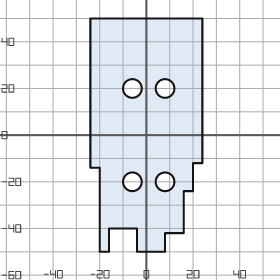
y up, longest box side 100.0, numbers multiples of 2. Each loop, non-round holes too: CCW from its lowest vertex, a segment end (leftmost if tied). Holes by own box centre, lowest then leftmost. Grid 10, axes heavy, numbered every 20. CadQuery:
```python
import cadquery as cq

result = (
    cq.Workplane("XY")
    .moveTo(-20.0, -50.0)
    .lineTo(-16.0, -50.0)
    .lineTo(-16.0, -40.0)
    .lineTo(-4.0, -40.0)
    .lineTo(-4.0, -50.0)
    .lineTo(8.0, -50.0)
    .lineTo(8.0, -42.0)
    .lineTo(16.0, -42.0)
    .lineTo(16.0, -24.0)
    .lineTo(20.0, -24.0)
    .lineTo(20.0, -12.0)
    .lineTo(24.0, -12.0)
    .lineTo(24.0, 50.0)
    .lineTo(-24.0, 50.0)
    .lineTo(-24.0, -14.0)
    .lineTo(-20.0, -14.0)
    .close()
    .moveTo(-6.0, -20.0)
    .circle(4.0)
    .moveTo(8.0, -20.0)
    .circle(4.0)
    .moveTo(-6.0, 20.0)
    .circle(4.0)
    .moveTo(8.0, 20.0)
    .circle(4.0)
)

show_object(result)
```